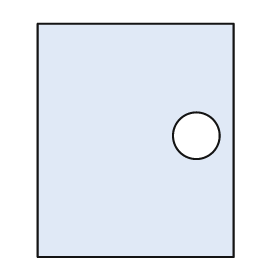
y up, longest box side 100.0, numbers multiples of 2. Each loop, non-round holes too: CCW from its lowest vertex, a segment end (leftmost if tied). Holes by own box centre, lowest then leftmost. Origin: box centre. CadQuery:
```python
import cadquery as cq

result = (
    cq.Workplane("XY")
    .moveTo(-42.0, -50.0)
    .lineTo(42.0, -50.0)
    .lineTo(42.0, 50.0)
    .lineTo(-42.0, 50.0)
    .close()
    .moveTo(26.0, 2.0)
    .circle(10.0)
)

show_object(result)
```